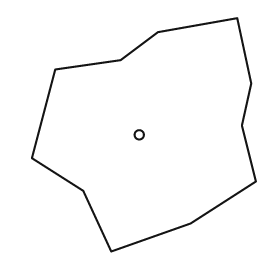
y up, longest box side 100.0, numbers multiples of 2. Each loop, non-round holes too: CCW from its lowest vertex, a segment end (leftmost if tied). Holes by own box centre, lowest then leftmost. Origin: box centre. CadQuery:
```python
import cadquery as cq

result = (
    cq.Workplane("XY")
    .moveTo(-14.0, -50.0)
    .lineTo(20.0, -38.0)
    .lineTo(48.0, -20.0)
    .lineTo(42.0, 4.0)
    .lineTo(46.0, 22.0)
    .lineTo(40.0, 50.0)
    .lineTo(6.0, 44.0)
    .lineTo(-10.0, 32.0)
    .lineTo(-38.0, 28.0)
    .lineTo(-48.0, -10.0)
    .lineTo(-26.0, -24.0)
    .close()
    .moveTo(-2.0, 0.0)
    .circle(2.0)
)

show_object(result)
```